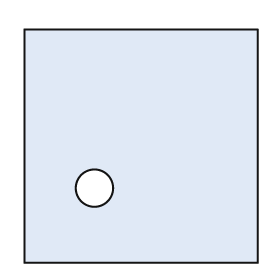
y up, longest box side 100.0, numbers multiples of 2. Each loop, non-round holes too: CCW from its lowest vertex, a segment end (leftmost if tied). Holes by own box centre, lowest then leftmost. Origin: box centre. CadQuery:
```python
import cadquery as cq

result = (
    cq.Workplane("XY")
    .moveTo(-50.0, -50.0)
    .lineTo(50.0, -50.0)
    .lineTo(50.0, 50.0)
    .lineTo(-50.0, 50.0)
    .close()
    .moveTo(-20.0, -18.0)
    .circle(8.0)
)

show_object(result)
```